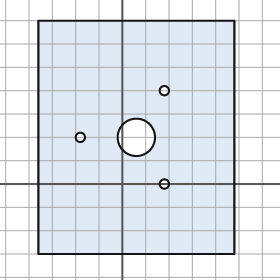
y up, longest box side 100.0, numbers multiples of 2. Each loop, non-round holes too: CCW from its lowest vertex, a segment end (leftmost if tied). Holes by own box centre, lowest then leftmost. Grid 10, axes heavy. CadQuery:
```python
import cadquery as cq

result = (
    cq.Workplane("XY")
    .moveTo(-36.0, -30.0)
    .lineTo(48.0, -30.0)
    .lineTo(48.0, 70.0)
    .lineTo(-36.0, 70.0)
    .close()
    .moveTo(18.0, 0.0)
    .circle(2.0)
    .moveTo(-18.0, 20.0)
    .circle(2.0)
    .moveTo(6.0, 20.0)
    .circle(8.0)
    .moveTo(18.0, 40.0)
    .circle(2.0)
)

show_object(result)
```